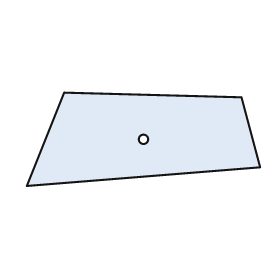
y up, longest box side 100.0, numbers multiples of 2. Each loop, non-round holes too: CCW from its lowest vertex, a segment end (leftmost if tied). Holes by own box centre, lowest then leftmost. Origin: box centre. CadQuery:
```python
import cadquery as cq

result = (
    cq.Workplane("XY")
    .moveTo(-50.0, -20.0)
    .lineTo(50.0, -12.0)
    .lineTo(42.0, 18.0)
    .lineTo(-34.0, 20.0)
    .close()
    .moveTo(0.0, 0.0)
    .circle(2.0)
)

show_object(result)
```